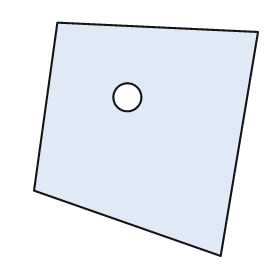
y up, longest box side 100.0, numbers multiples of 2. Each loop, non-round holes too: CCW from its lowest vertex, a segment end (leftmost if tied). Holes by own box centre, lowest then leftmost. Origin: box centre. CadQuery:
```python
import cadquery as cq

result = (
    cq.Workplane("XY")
    .moveTo(32.0, -50.0)
    .lineTo(48.0, 46.0)
    .lineTo(-38.0, 50.0)
    .lineTo(-48.0, -22.0)
    .close()
    .moveTo(-8.0, 18.0)
    .circle(6.0)
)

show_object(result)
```